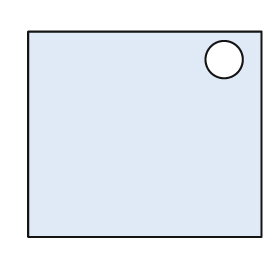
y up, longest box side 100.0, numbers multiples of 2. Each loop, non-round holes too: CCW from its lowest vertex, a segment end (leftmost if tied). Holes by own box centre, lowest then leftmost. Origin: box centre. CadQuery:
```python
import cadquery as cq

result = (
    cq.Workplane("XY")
    .moveTo(-50.0, -44.0)
    .lineTo(50.0, -44.0)
    .lineTo(50.0, 44.0)
    .lineTo(-50.0, 44.0)
    .close()
    .moveTo(34.0, 32.0)
    .circle(8.0)
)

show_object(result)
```